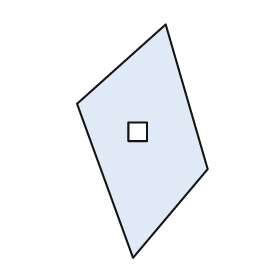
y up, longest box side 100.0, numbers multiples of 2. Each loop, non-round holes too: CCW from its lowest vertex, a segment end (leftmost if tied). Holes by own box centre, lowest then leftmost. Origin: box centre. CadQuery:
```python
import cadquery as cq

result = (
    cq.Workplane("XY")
    .moveTo(-4.0, -50.0)
    .lineTo(28.0, -12.0)
    .lineTo(10.0, 50.0)
    .lineTo(-28.0, 16.0)
    .close()
    .moveTo(-6.0, 0.0)
    .lineTo(2.0, 0.0)
    .lineTo(2.0, 8.0)
    .lineTo(-6.0, 8.0)
    .close()
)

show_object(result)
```